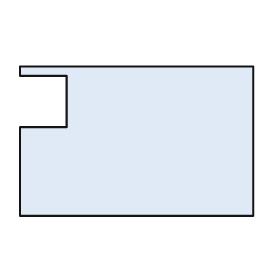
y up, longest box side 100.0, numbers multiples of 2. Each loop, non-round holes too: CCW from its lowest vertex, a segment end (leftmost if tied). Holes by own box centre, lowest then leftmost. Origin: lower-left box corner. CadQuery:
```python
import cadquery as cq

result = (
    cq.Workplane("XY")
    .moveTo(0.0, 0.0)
    .lineTo(100.0, 0.0)
    .lineTo(100.0, 64.0)
    .lineTo(0.0, 64.0)
    .lineTo(0.0, 60.0)
    .lineTo(20.0, 60.0)
    .lineTo(20.0, 38.0)
    .lineTo(0.0, 38.0)
    .close()
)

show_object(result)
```